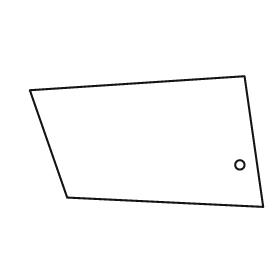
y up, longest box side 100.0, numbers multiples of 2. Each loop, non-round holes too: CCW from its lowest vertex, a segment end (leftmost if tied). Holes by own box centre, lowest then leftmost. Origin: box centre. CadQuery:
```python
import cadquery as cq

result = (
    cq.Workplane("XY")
    .moveTo(50.0, -28.0)
    .lineTo(42.0, 28.0)
    .lineTo(-50.0, 22.0)
    .lineTo(-34.0, -24.0)
    .close()
    .moveTo(40.0, -10.0)
    .circle(2.0)
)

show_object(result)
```